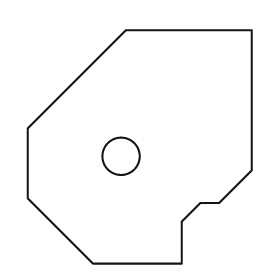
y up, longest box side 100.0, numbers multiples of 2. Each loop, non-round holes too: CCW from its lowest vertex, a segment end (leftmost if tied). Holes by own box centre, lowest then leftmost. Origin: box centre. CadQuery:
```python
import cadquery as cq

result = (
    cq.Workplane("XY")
    .moveTo(-20.0, -50.0)
    .lineTo(18.0, -50.0)
    .lineTo(18.0, -32.0)
    .lineTo(26.0, -24.0)
    .lineTo(34.0, -24.0)
    .lineTo(48.0, -10.0)
    .lineTo(48.0, 50.0)
    .lineTo(-6.0, 50.0)
    .lineTo(-48.0, 8.0)
    .lineTo(-48.0, -22.0)
    .close()
    .moveTo(-8.0, -4.0)
    .circle(8.0)
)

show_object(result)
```